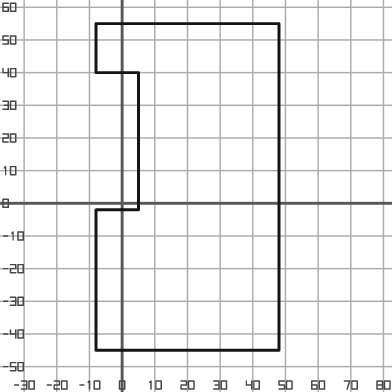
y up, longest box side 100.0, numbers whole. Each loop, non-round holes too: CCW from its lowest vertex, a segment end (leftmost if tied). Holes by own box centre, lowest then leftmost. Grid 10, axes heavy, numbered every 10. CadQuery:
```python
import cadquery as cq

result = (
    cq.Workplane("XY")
    .moveTo(-8.0, -45.0)
    .lineTo(48.0, -45.0)
    .lineTo(48.0, 55.0)
    .lineTo(-8.0, 55.0)
    .lineTo(-8.0, 40.0)
    .lineTo(5.0, 40.0)
    .lineTo(5.0, -2.0)
    .lineTo(-8.0, -2.0)
    .close()
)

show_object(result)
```